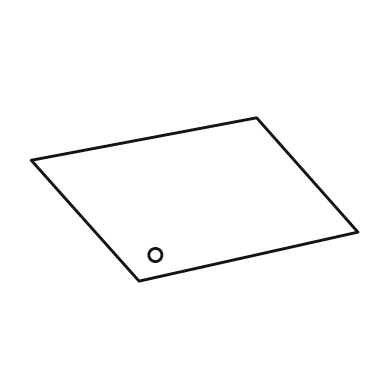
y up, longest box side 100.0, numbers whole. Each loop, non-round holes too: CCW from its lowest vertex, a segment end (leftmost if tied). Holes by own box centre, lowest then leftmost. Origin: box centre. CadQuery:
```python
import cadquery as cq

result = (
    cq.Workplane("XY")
    .moveTo(-17.0, -25.0)
    .lineTo(50.0, -10.0)
    .lineTo(19.0, 25.0)
    .lineTo(-50.0, 12.0)
    .close()
    .moveTo(-12.0, -17.0)
    .circle(2.0)
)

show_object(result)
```